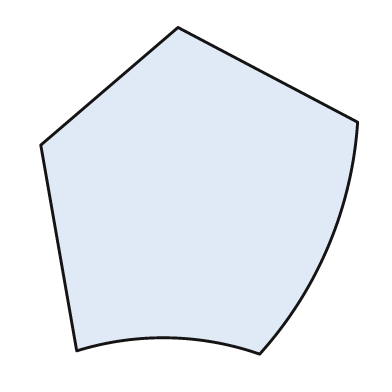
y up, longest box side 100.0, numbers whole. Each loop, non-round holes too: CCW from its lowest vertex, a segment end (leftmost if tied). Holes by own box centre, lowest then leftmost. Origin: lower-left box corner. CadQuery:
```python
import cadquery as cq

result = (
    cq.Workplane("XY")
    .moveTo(67.0, 0.0)
    .threePointArc((88.0, 33.0), (97.0, 71.0))
    .lineTo(42.0, 100.0)
    .lineTo(0.0, 64.0)
    .lineTo(11.0, 1.0)
    .threePointArc((39.0, 5.0), (67.0, 0.0))
    .close()
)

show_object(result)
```